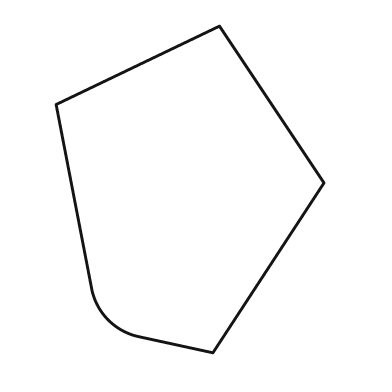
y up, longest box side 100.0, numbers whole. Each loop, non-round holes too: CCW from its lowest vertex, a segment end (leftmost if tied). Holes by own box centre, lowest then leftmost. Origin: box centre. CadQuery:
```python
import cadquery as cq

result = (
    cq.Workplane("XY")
    .moveTo(7.0, -50.0)
    .lineTo(41.0, 2.0)
    .lineTo(9.0, 50.0)
    .lineTo(-41.0, 26.0)
    .lineTo(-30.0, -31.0)
    .threePointArc((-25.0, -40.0), (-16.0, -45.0))
    .close()
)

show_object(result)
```